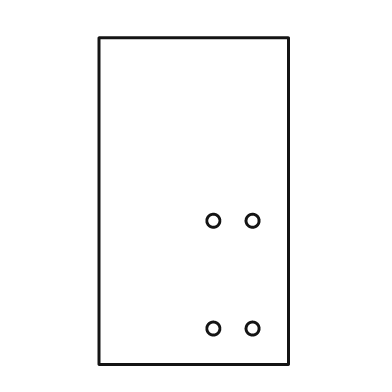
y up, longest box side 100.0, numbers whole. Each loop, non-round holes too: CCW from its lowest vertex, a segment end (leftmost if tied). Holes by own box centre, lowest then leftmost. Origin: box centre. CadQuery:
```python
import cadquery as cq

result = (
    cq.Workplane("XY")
    .moveTo(-29.0, -50.0)
    .lineTo(29.0, -50.0)
    .lineTo(29.0, 50.0)
    .lineTo(-29.0, 50.0)
    .close()
    .moveTo(6.0, -39.0)
    .circle(2.0)
    .moveTo(18.0, -39.0)
    .circle(2.0)
    .moveTo(6.0, -6.0)
    .circle(2.0)
    .moveTo(18.0, -6.0)
    .circle(2.0)
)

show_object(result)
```